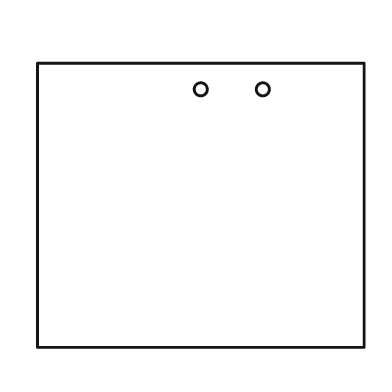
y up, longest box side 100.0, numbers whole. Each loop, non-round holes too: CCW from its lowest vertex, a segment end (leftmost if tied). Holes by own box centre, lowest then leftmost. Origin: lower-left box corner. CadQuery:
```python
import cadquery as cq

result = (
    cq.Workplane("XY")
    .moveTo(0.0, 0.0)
    .lineTo(100.0, 0.0)
    .lineTo(100.0, 87.0)
    .lineTo(0.0, 87.0)
    .close()
    .moveTo(50.0, 79.0)
    .circle(2.0)
    .moveTo(69.0, 79.0)
    .circle(2.0)
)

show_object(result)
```